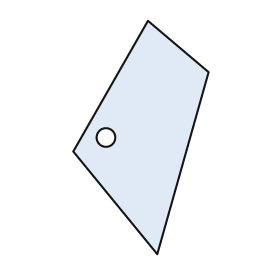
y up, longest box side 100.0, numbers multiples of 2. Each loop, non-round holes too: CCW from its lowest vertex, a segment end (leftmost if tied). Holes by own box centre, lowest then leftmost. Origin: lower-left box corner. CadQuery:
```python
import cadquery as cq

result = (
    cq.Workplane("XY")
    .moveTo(36.0, 0.0)
    .lineTo(58.0, 78.0)
    .lineTo(32.0, 100.0)
    .lineTo(0.0, 44.0)
    .close()
    .moveTo(14.0, 50.0)
    .circle(4.0)
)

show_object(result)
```